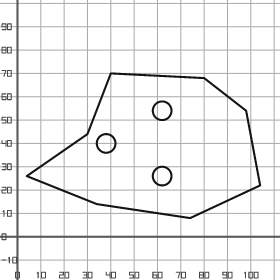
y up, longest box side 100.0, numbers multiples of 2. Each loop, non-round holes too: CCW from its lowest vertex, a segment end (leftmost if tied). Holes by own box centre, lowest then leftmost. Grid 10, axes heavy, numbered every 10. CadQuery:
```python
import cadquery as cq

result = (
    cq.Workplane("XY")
    .moveTo(74.0, 8.0)
    .lineTo(104.0, 22.0)
    .lineTo(98.0, 54.0)
    .lineTo(80.0, 68.0)
    .lineTo(40.0, 70.0)
    .lineTo(30.0, 44.0)
    .lineTo(4.0, 26.0)
    .lineTo(34.0, 14.0)
    .close()
    .moveTo(62.0, 26.0)
    .circle(4.0)
    .moveTo(38.0, 40.0)
    .circle(4.0)
    .moveTo(62.0, 54.0)
    .circle(4.0)
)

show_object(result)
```